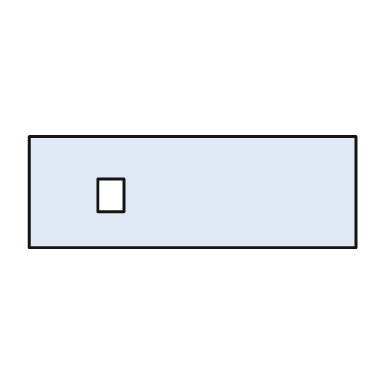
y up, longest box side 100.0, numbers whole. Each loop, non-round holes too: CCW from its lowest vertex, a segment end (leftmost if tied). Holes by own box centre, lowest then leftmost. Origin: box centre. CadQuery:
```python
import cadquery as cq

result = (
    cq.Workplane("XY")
    .moveTo(-50.0, -17.0)
    .lineTo(50.0, -17.0)
    .lineTo(50.0, 17.0)
    .lineTo(-50.0, 17.0)
    .close()
    .moveTo(-29.0, -6.0)
    .lineTo(-21.0, -6.0)
    .lineTo(-21.0, 4.0)
    .lineTo(-29.0, 4.0)
    .close()
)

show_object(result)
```